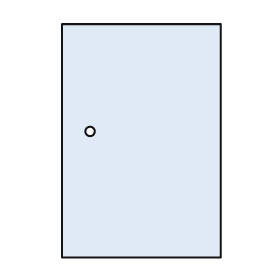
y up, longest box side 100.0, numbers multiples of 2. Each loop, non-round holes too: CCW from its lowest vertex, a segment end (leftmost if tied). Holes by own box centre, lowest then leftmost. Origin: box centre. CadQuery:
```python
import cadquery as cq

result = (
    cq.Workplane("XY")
    .moveTo(-34.0, -50.0)
    .lineTo(34.0, -50.0)
    .lineTo(34.0, 50.0)
    .lineTo(-34.0, 50.0)
    .close()
    .moveTo(-22.0, 4.0)
    .circle(2.0)
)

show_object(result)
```